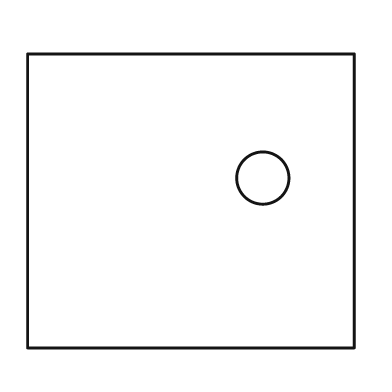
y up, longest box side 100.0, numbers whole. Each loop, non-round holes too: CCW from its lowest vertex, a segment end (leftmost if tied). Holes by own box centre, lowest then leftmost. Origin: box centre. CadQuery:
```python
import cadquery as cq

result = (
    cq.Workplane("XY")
    .moveTo(-50.0, -45.0)
    .lineTo(50.0, -45.0)
    .lineTo(50.0, 45.0)
    .lineTo(-50.0, 45.0)
    .close()
    .moveTo(22.0, 7.0)
    .circle(8.0)
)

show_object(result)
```